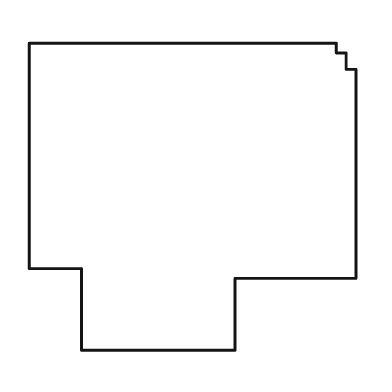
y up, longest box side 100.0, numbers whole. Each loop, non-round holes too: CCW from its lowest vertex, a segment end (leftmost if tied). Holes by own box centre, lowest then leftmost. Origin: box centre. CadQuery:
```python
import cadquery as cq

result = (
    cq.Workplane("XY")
    .moveTo(-34.0, -47.0)
    .lineTo(13.0, -47.0)
    .lineTo(13.0, -25.0)
    .lineTo(50.0, -25.0)
    .lineTo(50.0, 39.0)
    .lineTo(47.0, 39.0)
    .lineTo(47.0, 44.0)
    .lineTo(44.0, 44.0)
    .lineTo(44.0, 47.0)
    .lineTo(-50.0, 47.0)
    .lineTo(-50.0, -22.0)
    .lineTo(-34.0, -22.0)
    .close()
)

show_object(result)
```